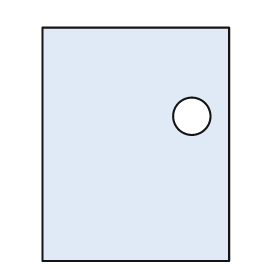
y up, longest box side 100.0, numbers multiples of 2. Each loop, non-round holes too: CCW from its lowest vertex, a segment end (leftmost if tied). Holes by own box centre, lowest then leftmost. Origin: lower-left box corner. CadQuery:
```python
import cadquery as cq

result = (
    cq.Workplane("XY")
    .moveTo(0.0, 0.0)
    .lineTo(80.0, 0.0)
    .lineTo(80.0, 100.0)
    .lineTo(0.0, 100.0)
    .close()
    .moveTo(64.0, 62.0)
    .circle(8.0)
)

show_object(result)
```